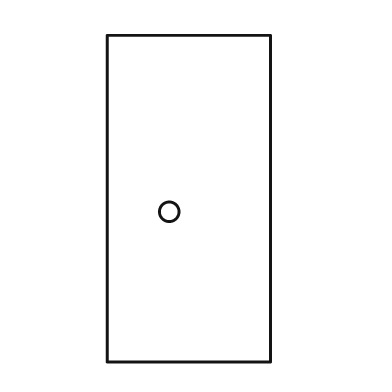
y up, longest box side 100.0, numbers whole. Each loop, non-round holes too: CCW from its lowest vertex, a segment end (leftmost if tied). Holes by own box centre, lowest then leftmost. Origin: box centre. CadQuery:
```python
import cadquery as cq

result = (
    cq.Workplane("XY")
    .moveTo(-25.0, -50.0)
    .lineTo(25.0, -50.0)
    .lineTo(25.0, 50.0)
    .lineTo(-25.0, 50.0)
    .close()
    .moveTo(-6.0, -4.0)
    .circle(3.0)
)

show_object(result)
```